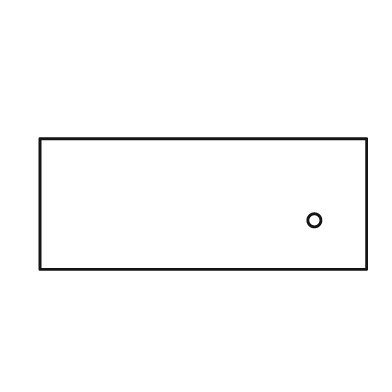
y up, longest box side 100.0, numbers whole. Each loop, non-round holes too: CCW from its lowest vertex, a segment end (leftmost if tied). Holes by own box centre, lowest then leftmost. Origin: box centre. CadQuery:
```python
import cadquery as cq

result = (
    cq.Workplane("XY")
    .moveTo(-50.0, -20.0)
    .lineTo(50.0, -20.0)
    .lineTo(50.0, 20.0)
    .lineTo(-50.0, 20.0)
    .close()
    .moveTo(34.0, -5.0)
    .circle(2.0)
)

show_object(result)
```